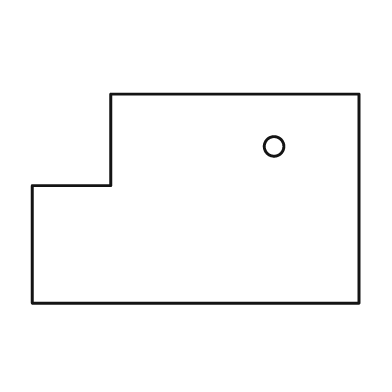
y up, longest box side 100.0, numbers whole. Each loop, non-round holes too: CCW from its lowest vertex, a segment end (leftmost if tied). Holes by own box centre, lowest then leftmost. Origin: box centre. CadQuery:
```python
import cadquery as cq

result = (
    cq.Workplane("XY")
    .moveTo(-50.0, -32.0)
    .lineTo(50.0, -32.0)
    .lineTo(50.0, 32.0)
    .lineTo(-26.0, 32.0)
    .lineTo(-26.0, 4.0)
    .lineTo(-50.0, 4.0)
    .close()
    .moveTo(24.0, 16.0)
    .circle(3.0)
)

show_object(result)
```